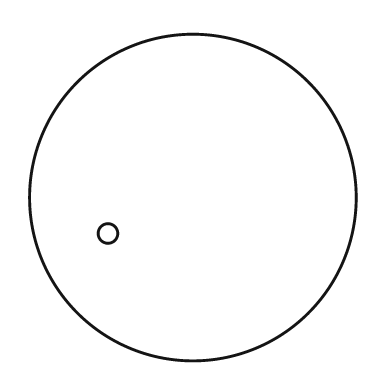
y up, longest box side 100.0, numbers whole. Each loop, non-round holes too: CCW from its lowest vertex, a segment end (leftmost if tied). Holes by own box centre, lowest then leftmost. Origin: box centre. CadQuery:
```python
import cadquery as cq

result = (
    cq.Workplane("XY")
    .moveTo(0.0, 0.0)
    .circle(50.0)
    .moveTo(-26.0, -11.0)
    .circle(3.0)
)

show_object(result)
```